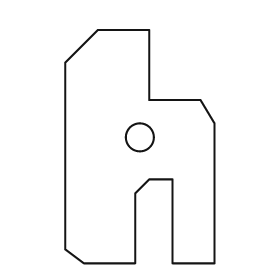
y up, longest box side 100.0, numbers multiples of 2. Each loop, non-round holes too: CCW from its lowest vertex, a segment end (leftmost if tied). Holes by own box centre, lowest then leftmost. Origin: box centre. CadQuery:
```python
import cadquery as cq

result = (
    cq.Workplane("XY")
    .moveTo(-24.0, -50.0)
    .lineTo(-2.0, -50.0)
    .lineTo(-2.0, -20.0)
    .lineTo(4.0, -14.0)
    .lineTo(14.0, -14.0)
    .lineTo(14.0, -50.0)
    .lineTo(32.0, -50.0)
    .lineTo(32.0, 10.0)
    .lineTo(26.0, 20.0)
    .lineTo(4.0, 20.0)
    .lineTo(4.0, 50.0)
    .lineTo(-18.0, 50.0)
    .lineTo(-32.0, 36.0)
    .lineTo(-32.0, -44.0)
    .close()
    .moveTo(0.0, 4.0)
    .circle(6.0)
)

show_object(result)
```